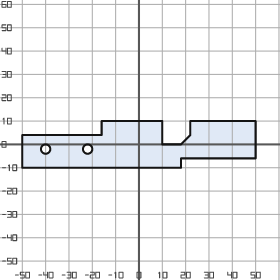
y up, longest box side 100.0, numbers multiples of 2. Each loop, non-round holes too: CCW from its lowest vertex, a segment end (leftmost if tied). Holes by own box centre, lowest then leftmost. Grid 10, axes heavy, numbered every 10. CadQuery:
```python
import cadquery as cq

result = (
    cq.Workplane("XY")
    .moveTo(-50.0, -10.0)
    .lineTo(18.0, -10.0)
    .lineTo(18.0, -6.0)
    .lineTo(50.0, -6.0)
    .lineTo(50.0, 10.0)
    .lineTo(22.0, 10.0)
    .lineTo(22.0, 4.0)
    .lineTo(18.0, 0.0)
    .lineTo(10.0, 0.0)
    .lineTo(10.0, 10.0)
    .lineTo(-16.0, 10.0)
    .lineTo(-16.0, 4.0)
    .lineTo(-50.0, 4.0)
    .close()
    .moveTo(-40.0, -2.0)
    .circle(2.0)
    .moveTo(-22.0, -2.0)
    .circle(2.0)
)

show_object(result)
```